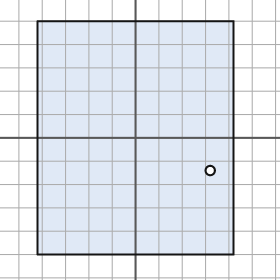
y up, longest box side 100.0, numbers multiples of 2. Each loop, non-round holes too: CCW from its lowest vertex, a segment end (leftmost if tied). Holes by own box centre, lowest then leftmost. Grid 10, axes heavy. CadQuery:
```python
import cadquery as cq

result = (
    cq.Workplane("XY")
    .moveTo(-42.0, -50.0)
    .lineTo(42.0, -50.0)
    .lineTo(42.0, 50.0)
    .lineTo(-42.0, 50.0)
    .close()
    .moveTo(32.0, -14.0)
    .circle(2.0)
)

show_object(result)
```